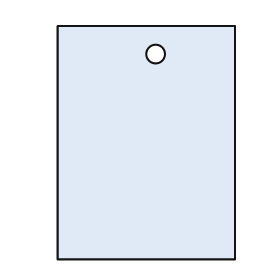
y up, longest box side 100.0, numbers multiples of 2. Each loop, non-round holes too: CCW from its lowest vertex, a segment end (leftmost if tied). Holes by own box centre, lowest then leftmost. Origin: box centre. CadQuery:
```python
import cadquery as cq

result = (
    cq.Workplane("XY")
    .moveTo(-38.0, -50.0)
    .lineTo(38.0, -50.0)
    .lineTo(38.0, 50.0)
    .lineTo(-38.0, 50.0)
    .close()
    .moveTo(4.0, 38.0)
    .circle(4.0)
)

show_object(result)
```